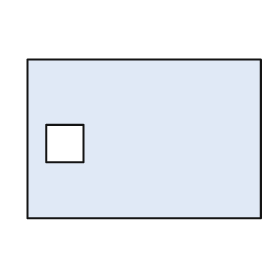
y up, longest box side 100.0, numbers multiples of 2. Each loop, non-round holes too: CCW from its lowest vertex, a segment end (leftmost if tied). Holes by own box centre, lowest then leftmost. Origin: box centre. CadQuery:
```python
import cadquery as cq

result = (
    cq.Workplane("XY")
    .moveTo(-50.0, -34.0)
    .lineTo(50.0, -34.0)
    .lineTo(50.0, 34.0)
    .lineTo(-50.0, 34.0)
    .close()
    .moveTo(-42.0, -10.0)
    .lineTo(-26.0, -10.0)
    .lineTo(-26.0, 6.0)
    .lineTo(-42.0, 6.0)
    .close()
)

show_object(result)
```